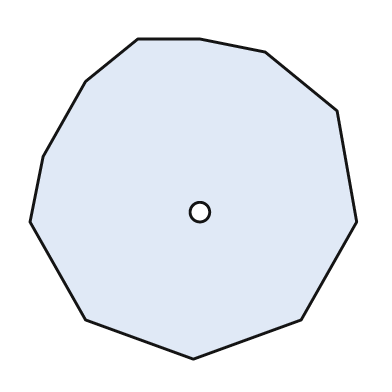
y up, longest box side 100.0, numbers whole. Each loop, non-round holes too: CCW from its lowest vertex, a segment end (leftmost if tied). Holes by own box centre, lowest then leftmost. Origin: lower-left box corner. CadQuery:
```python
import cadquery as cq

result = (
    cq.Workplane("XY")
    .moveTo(50.0, 0.0)
    .lineTo(83.0, 12.0)
    .lineTo(100.0, 42.0)
    .lineTo(94.0, 76.0)
    .lineTo(72.0, 94.0)
    .lineTo(52.0, 98.0)
    .lineTo(33.0, 98.0)
    .lineTo(17.0, 85.0)
    .lineTo(4.0, 62.0)
    .lineTo(0.0, 42.0)
    .lineTo(17.0, 12.0)
    .close()
    .moveTo(52.0, 45.0)
    .circle(3.0)
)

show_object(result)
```